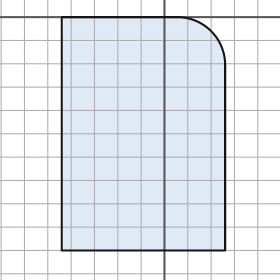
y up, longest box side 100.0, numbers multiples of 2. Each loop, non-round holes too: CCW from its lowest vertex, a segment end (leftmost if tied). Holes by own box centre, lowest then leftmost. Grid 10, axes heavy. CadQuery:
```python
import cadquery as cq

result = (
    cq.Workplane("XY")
    .moveTo(-44.0, -100.0)
    .lineTo(26.0, -100.0)
    .lineTo(26.0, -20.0)
    .threePointArc((20.0, -6.0), (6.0, 0.0))
    .lineTo(-44.0, 0.0)
    .close()
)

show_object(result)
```